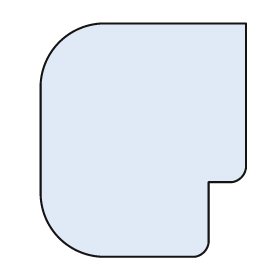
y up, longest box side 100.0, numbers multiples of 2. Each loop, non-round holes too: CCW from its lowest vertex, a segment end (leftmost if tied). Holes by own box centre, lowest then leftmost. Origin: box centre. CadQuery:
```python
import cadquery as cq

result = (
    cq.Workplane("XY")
    .moveTo(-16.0, -50.0)
    .lineTo(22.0, -50.0)
    .threePointArc((26.0, -48.0), (28.0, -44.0))
    .lineTo(28.0, -18.0)
    .lineTo(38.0, -18.0)
    .threePointArc((42.0, -16.0), (44.0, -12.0))
    .lineTo(44.0, 50.0)
    .lineTo(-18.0, 50.0)
    .threePointArc((-36.0, 42.0), (-44.0, 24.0))
    .lineTo(-44.0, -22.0)
    .threePointArc((-36.0, -42.0), (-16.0, -50.0))
    .close()
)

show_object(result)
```